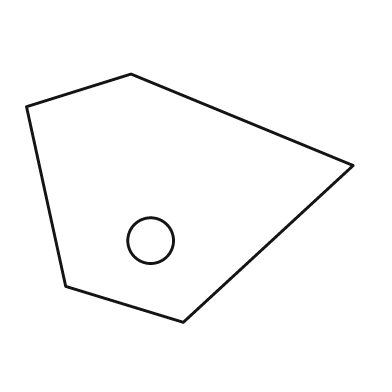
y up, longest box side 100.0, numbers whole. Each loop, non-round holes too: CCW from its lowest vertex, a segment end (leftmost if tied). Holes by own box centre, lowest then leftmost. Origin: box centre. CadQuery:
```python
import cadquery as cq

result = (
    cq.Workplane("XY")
    .moveTo(-2.0, -38.0)
    .lineTo(50.0, 10.0)
    .lineTo(-18.0, 38.0)
    .lineTo(-50.0, 28.0)
    .lineTo(-38.0, -27.0)
    .close()
    .moveTo(-12.0, -13.0)
    .circle(7.0)
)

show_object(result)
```